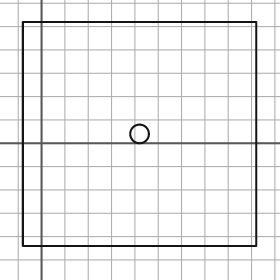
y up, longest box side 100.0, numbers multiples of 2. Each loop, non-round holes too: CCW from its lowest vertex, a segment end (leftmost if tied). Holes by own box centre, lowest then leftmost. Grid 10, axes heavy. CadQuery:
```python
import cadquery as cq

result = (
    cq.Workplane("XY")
    .moveTo(-8.0, -44.0)
    .lineTo(92.0, -44.0)
    .lineTo(92.0, 52.0)
    .lineTo(-8.0, 52.0)
    .close()
    .moveTo(42.0, 4.0)
    .circle(4.0)
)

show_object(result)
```